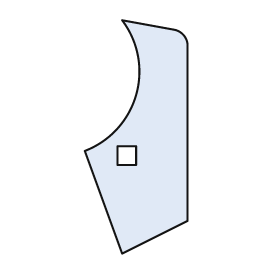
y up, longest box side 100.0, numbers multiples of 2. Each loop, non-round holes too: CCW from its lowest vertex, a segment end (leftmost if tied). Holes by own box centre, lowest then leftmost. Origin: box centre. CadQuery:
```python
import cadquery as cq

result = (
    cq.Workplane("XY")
    .moveTo(-6.0, -50.0)
    .lineTo(22.0, -36.0)
    .lineTo(22.0, 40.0)
    .threePointArc((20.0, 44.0), (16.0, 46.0))
    .lineTo(-6.0, 50.0)
    .threePointArc((0.0, 18.0), (-22.0, -6.0))
    .close()
    .moveTo(-8.0, -12.0)
    .lineTo(0.0, -12.0)
    .lineTo(0.0, -4.0)
    .lineTo(-8.0, -4.0)
    .close()
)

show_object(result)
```